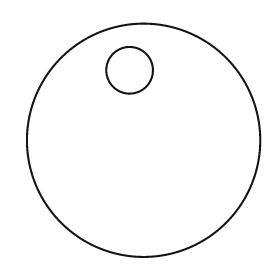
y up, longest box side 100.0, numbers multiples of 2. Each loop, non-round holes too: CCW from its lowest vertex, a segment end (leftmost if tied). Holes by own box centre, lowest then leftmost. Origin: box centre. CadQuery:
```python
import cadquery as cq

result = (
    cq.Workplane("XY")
    .moveTo(0.0, 0.0)
    .circle(50.0)
    .moveTo(-6.0, 30.0)
    .circle(10.0)
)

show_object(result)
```